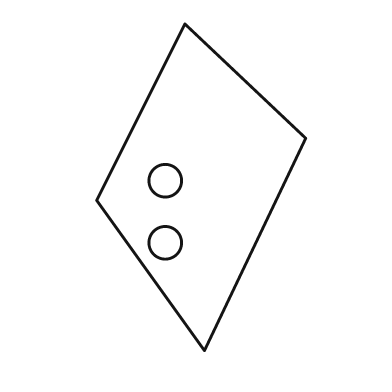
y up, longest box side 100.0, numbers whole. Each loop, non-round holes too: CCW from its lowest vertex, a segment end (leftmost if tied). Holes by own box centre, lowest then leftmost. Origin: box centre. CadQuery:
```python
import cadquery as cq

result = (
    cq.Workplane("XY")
    .moveTo(1.0, -50.0)
    .lineTo(32.0, 15.0)
    .lineTo(-5.0, 50.0)
    .lineTo(-32.0, -4.0)
    .close()
    .moveTo(-11.0, -17.0)
    .circle(5.0)
    .moveTo(-11.0, 2.0)
    .circle(5.0)
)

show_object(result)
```